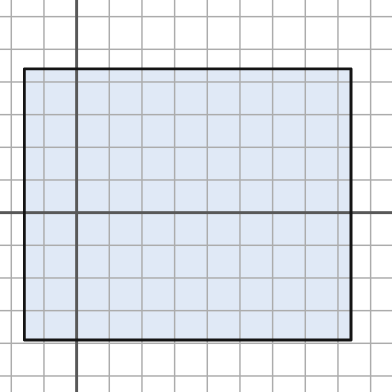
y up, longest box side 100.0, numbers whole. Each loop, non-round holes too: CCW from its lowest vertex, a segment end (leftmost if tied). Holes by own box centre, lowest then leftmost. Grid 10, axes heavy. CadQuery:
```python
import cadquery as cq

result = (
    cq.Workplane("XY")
    .moveTo(-16.0, -39.0)
    .lineTo(84.0, -39.0)
    .lineTo(84.0, 44.0)
    .lineTo(-16.0, 44.0)
    .close()
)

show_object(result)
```